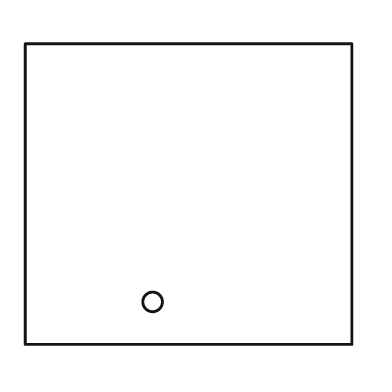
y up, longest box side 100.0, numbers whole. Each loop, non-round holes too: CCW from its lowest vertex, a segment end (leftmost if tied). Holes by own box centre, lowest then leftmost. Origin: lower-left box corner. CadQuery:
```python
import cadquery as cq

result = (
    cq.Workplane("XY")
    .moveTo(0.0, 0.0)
    .lineTo(100.0, 0.0)
    .lineTo(100.0, 92.0)
    .lineTo(0.0, 92.0)
    .close()
    .moveTo(39.0, 13.0)
    .circle(3.0)
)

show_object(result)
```